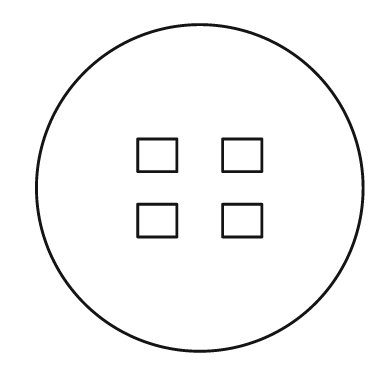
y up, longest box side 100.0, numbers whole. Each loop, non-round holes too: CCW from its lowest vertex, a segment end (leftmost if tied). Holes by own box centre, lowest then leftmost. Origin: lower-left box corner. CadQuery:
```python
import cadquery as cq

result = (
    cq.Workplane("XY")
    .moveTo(50.0, 50.0)
    .circle(50.0)
    .moveTo(31.0, 35.0)
    .lineTo(43.0, 35.0)
    .lineTo(43.0, 45.0)
    .lineTo(31.0, 45.0)
    .close()
    .moveTo(57.0, 35.0)
    .lineTo(69.0, 35.0)
    .lineTo(69.0, 45.0)
    .lineTo(57.0, 45.0)
    .close()
    .moveTo(31.0, 55.0)
    .lineTo(43.0, 55.0)
    .lineTo(43.0, 65.0)
    .lineTo(31.0, 65.0)
    .close()
    .moveTo(57.0, 55.0)
    .lineTo(69.0, 55.0)
    .lineTo(69.0, 65.0)
    .lineTo(57.0, 65.0)
    .close()
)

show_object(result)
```